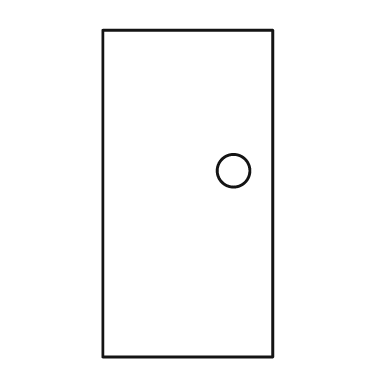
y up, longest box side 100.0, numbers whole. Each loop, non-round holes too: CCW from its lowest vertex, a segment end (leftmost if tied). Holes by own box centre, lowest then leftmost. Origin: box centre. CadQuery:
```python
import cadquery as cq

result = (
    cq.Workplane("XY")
    .moveTo(-26.0, -50.0)
    .lineTo(26.0, -50.0)
    .lineTo(26.0, 50.0)
    .lineTo(-26.0, 50.0)
    .close()
    .moveTo(14.0, 7.0)
    .circle(5.0)
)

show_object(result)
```